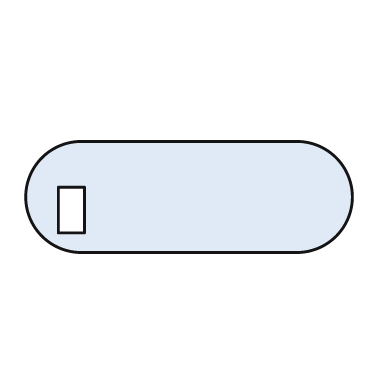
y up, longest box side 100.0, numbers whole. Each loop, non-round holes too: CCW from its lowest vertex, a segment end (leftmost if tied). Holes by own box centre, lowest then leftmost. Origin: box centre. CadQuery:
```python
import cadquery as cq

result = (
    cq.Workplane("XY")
    .moveTo(-33.0, -17.0)
    .lineTo(33.0, -17.0)
    .threePointArc((50.0, 0.0), (33.0, 17.0))
    .lineTo(-33.0, 17.0)
    .threePointArc((-50.0, 0.0), (-33.0, -17.0))
    .close()
    .moveTo(-40.0, -11.0)
    .lineTo(-32.0, -11.0)
    .lineTo(-32.0, 3.0)
    .lineTo(-40.0, 3.0)
    .close()
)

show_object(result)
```